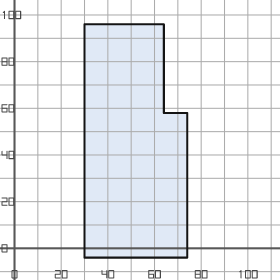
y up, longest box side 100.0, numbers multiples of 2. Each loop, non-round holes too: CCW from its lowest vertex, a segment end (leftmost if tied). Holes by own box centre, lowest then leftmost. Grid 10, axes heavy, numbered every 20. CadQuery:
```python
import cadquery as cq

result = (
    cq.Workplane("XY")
    .moveTo(30.0, -4.0)
    .lineTo(74.0, -4.0)
    .lineTo(74.0, 58.0)
    .lineTo(64.0, 58.0)
    .lineTo(64.0, 96.0)
    .lineTo(30.0, 96.0)
    .close()
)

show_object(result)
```